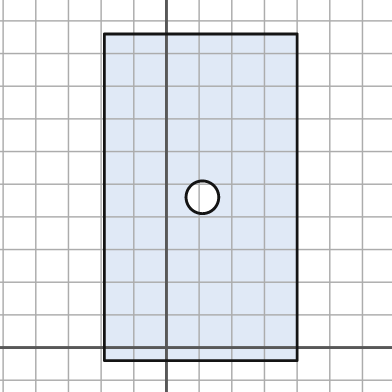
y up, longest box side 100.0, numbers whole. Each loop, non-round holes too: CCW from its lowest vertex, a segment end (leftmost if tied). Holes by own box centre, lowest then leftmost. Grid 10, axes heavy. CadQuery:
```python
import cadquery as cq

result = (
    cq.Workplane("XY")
    .moveTo(-19.0, -4.0)
    .lineTo(40.0, -4.0)
    .lineTo(40.0, 96.0)
    .lineTo(-19.0, 96.0)
    .close()
    .moveTo(11.0, 46.0)
    .circle(5.0)
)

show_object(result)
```